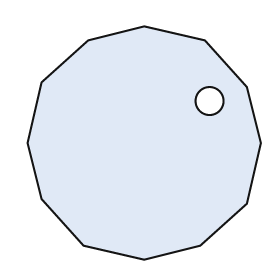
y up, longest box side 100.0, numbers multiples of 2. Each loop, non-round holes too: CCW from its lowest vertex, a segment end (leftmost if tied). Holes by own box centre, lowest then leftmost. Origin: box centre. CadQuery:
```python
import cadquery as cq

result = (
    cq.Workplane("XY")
    .moveTo(0.0, -50.0)
    .lineTo(24.0, -44.0)
    .lineTo(44.0, -26.0)
    .lineTo(50.0, 0.0)
    .lineTo(44.0, 24.0)
    .lineTo(26.0, 44.0)
    .lineTo(0.0, 50.0)
    .lineTo(-24.0, 44.0)
    .lineTo(-44.0, 26.0)
    .lineTo(-50.0, 0.0)
    .lineTo(-44.0, -24.0)
    .lineTo(-26.0, -44.0)
    .close()
    .moveTo(28.0, 18.0)
    .circle(6.0)
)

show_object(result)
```